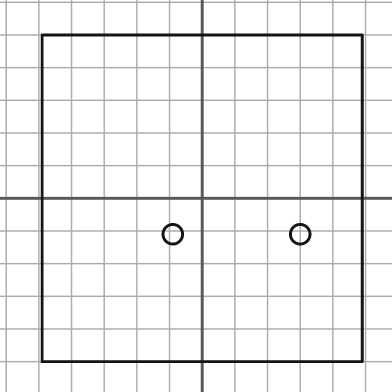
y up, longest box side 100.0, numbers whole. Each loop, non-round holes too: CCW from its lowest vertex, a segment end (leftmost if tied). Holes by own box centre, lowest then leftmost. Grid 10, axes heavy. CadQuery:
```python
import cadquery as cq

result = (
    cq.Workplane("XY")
    .moveTo(-49.0, -50.0)
    .lineTo(49.0, -50.0)
    .lineTo(49.0, 50.0)
    .lineTo(-49.0, 50.0)
    .close()
    .moveTo(-9.0, -11.0)
    .circle(3.0)
    .moveTo(30.0, -11.0)
    .circle(3.0)
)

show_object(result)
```